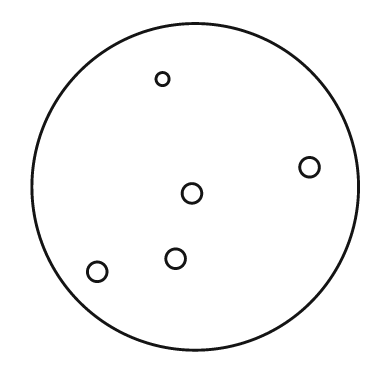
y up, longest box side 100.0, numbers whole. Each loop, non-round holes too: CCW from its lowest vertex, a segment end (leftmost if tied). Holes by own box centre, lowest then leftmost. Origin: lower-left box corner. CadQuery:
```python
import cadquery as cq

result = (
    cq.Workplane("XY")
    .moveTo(50.0, 50.0)
    .circle(50.0)
    .moveTo(20.0, 24.0)
    .circle(3.0)
    .moveTo(44.0, 28.0)
    .circle(3.0)
    .moveTo(49.0, 48.0)
    .circle(3.0)
    .moveTo(85.0, 56.0)
    .circle(3.0)
    .moveTo(40.0, 83.0)
    .circle(2.0)
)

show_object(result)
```